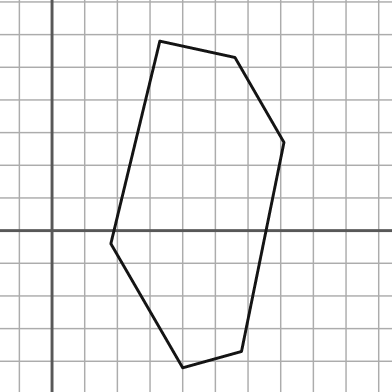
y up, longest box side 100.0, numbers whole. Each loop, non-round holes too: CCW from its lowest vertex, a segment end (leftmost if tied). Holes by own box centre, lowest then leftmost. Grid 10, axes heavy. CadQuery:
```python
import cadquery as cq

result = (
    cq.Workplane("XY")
    .moveTo(40.0, -42.0)
    .lineTo(58.0, -37.0)
    .lineTo(71.0, 27.0)
    .lineTo(56.0, 53.0)
    .lineTo(33.0, 58.0)
    .lineTo(18.0, -4.0)
    .close()
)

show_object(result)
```